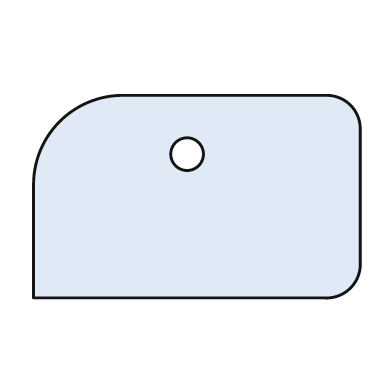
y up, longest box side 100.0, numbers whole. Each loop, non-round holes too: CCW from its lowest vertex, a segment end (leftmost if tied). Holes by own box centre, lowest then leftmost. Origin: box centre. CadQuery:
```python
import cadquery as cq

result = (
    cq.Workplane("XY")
    .moveTo(-50.0, -31.0)
    .lineTo(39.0, -31.0)
    .threePointArc((47.0, -28.0), (50.0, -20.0))
    .lineTo(50.0, 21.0)
    .threePointArc((47.0, 28.0), (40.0, 31.0))
    .lineTo(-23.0, 31.0)
    .threePointArc((-42.0, 23.0), (-50.0, 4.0))
    .close()
    .moveTo(-3.0, 13.0)
    .circle(5.0)
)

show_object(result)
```